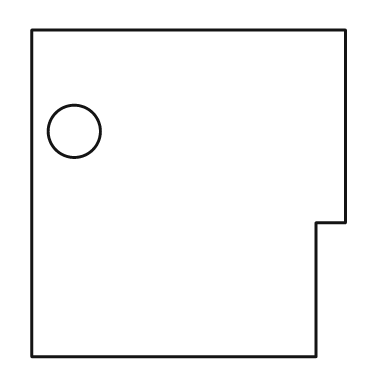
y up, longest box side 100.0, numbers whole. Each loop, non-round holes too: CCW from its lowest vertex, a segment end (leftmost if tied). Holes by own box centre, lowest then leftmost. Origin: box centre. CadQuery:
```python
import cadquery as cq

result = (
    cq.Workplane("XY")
    .moveTo(-48.0, -50.0)
    .lineTo(39.0, -50.0)
    .lineTo(39.0, -9.0)
    .lineTo(48.0, -9.0)
    .lineTo(48.0, 50.0)
    .lineTo(-48.0, 50.0)
    .close()
    .moveTo(-35.0, 19.0)
    .circle(8.0)
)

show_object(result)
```